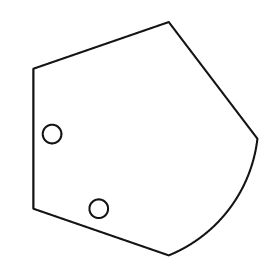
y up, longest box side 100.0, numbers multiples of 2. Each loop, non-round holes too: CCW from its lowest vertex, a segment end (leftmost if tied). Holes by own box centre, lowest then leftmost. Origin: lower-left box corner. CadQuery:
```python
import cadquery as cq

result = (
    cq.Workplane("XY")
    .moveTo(58.0, 0.0)
    .threePointArc((84.0, 20.0), (96.0, 50.0))
    .lineTo(58.0, 100.0)
    .lineTo(0.0, 80.0)
    .lineTo(0.0, 20.0)
    .close()
    .moveTo(28.0, 20.0)
    .circle(4.0)
    .moveTo(8.0, 52.0)
    .circle(4.0)
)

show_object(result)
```